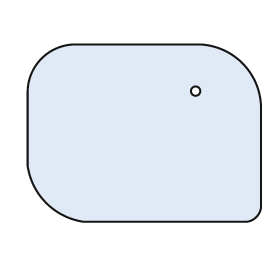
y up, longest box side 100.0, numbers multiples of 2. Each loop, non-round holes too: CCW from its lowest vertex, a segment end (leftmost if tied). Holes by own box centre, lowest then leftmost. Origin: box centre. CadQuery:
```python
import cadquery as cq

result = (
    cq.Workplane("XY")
    .moveTo(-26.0, -38.0)
    .lineTo(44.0, -38.0)
    .threePointArc((48.0, -36.0), (50.0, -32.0))
    .lineTo(50.0, 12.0)
    .threePointArc((42.0, 30.0), (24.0, 38.0))
    .lineTo(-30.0, 38.0)
    .threePointArc((-44.0, 32.0), (-50.0, 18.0))
    .lineTo(-50.0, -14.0)
    .threePointArc((-42.0, -30.0), (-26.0, -38.0))
    .close()
    .moveTo(22.0, 18.0)
    .circle(2.0)
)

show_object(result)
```